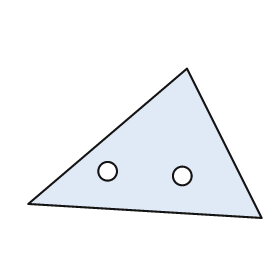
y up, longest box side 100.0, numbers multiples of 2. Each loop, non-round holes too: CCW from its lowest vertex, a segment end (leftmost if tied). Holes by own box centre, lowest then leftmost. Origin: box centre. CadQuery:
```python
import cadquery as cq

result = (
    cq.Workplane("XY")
    .moveTo(50.0, -32.0)
    .lineTo(18.0, 32.0)
    .lineTo(-50.0, -26.0)
    .close()
    .moveTo(16.0, -14.0)
    .circle(4.0)
    .moveTo(-16.0, -12.0)
    .circle(4.0)
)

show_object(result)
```